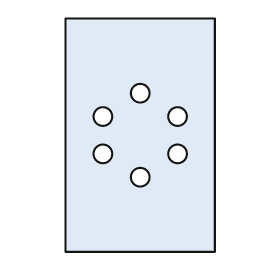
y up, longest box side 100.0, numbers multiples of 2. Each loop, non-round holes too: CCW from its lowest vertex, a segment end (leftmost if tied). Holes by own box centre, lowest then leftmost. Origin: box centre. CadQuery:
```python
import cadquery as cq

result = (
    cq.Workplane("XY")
    .moveTo(-32.0, -50.0)
    .lineTo(32.0, -50.0)
    .lineTo(32.0, 50.0)
    .lineTo(-32.0, 50.0)
    .close()
    .moveTo(0.0, -18.0)
    .circle(4.0)
    .moveTo(-16.0, -8.0)
    .circle(4.0)
    .moveTo(16.0, -8.0)
    .circle(4.0)
    .moveTo(-16.0, 8.0)
    .circle(4.0)
    .moveTo(16.0, 8.0)
    .circle(4.0)
    .moveTo(0.0, 18.0)
    .circle(4.0)
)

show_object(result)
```